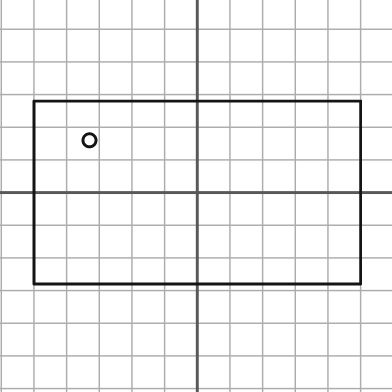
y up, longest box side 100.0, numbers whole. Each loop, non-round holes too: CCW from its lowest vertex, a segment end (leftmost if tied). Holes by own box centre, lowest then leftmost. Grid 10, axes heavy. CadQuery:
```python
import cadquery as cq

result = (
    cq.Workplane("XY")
    .moveTo(-50.0, -28.0)
    .lineTo(50.0, -28.0)
    .lineTo(50.0, 28.0)
    .lineTo(-50.0, 28.0)
    .close()
    .moveTo(-33.0, 16.0)
    .circle(2.0)
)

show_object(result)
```